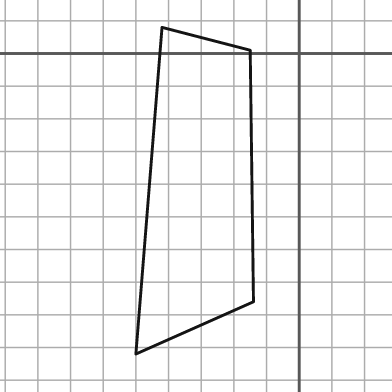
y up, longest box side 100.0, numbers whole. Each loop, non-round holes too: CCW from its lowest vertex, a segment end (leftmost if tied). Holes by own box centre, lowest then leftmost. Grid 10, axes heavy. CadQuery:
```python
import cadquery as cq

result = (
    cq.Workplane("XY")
    .moveTo(-50.0, -92.0)
    .lineTo(-14.0, -76.0)
    .lineTo(-15.0, 1.0)
    .lineTo(-42.0, 8.0)
    .close()
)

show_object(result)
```